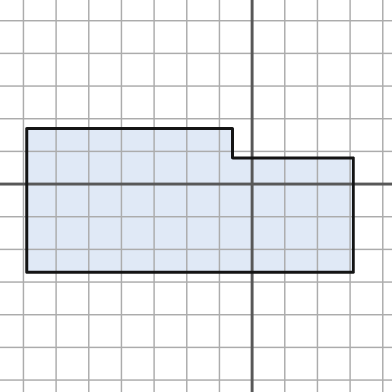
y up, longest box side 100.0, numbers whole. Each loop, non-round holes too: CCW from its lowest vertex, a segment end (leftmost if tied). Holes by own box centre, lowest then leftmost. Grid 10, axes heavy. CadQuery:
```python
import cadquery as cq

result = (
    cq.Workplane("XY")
    .moveTo(-69.0, -27.0)
    .lineTo(31.0, -27.0)
    .lineTo(31.0, 8.0)
    .lineTo(-6.0, 8.0)
    .lineTo(-6.0, 17.0)
    .lineTo(-69.0, 17.0)
    .close()
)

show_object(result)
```